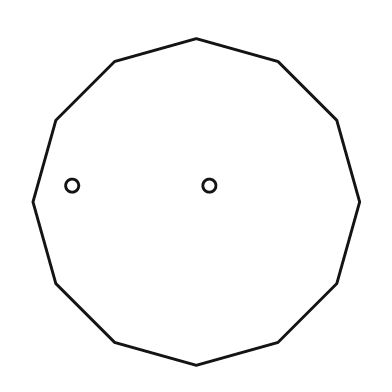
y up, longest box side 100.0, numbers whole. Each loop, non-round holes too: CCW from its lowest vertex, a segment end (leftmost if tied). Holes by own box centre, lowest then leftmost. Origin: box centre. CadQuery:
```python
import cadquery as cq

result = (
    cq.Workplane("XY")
    .moveTo(0.0, -50.0)
    .lineTo(25.0, -43.0)
    .lineTo(43.0, -25.0)
    .lineTo(50.0, 0.0)
    .lineTo(43.0, 25.0)
    .lineTo(25.0, 43.0)
    .lineTo(0.0, 50.0)
    .lineTo(-25.0, 43.0)
    .lineTo(-43.0, 25.0)
    .lineTo(-50.0, 0.0)
    .lineTo(-43.0, -25.0)
    .lineTo(-25.0, -43.0)
    .close()
    .moveTo(-38.0, 5.0)
    .circle(2.0)
    .moveTo(4.0, 5.0)
    .circle(2.0)
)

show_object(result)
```